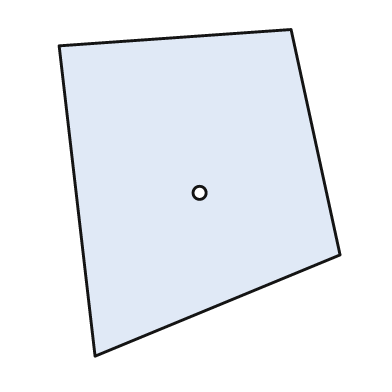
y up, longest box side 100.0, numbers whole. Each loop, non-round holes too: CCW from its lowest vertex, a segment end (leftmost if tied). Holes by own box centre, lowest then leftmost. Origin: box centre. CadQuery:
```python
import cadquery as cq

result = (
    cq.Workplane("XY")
    .moveTo(-32.0, -50.0)
    .lineTo(43.0, -19.0)
    .lineTo(28.0, 50.0)
    .lineTo(-43.0, 45.0)
    .close()
    .moveTo(0.0, 0.0)
    .circle(2.0)
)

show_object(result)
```